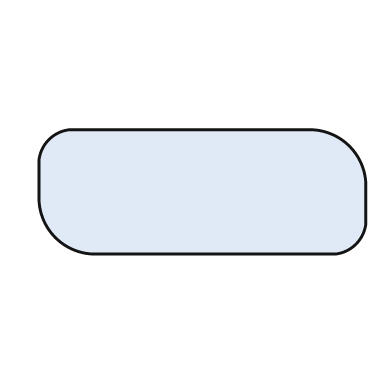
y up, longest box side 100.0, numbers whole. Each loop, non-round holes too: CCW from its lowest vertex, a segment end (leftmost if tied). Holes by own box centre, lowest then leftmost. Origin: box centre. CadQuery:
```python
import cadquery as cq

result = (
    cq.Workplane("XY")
    .moveTo(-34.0, -19.0)
    .lineTo(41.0, -19.0)
    .threePointArc((47.0, -16.0), (50.0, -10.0))
    .lineTo(50.0, 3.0)
    .threePointArc((45.0, 14.0), (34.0, 19.0))
    .lineTo(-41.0, 19.0)
    .threePointArc((-47.0, 16.0), (-50.0, 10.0))
    .lineTo(-50.0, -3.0)
    .threePointArc((-45.0, -14.0), (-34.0, -19.0))
    .close()
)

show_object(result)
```